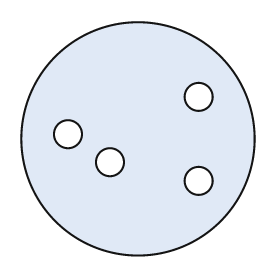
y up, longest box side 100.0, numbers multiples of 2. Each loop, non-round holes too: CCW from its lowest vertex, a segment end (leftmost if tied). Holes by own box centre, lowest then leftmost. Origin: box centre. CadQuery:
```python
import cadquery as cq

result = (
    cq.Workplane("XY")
    .moveTo(0.0, 0.0)
    .circle(50.0)
    .moveTo(26.0, -18.0)
    .circle(6.0)
    .moveTo(-12.0, -10.0)
    .circle(6.0)
    .moveTo(-30.0, 2.0)
    .circle(6.0)
    .moveTo(26.0, 18.0)
    .circle(6.0)
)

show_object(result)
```